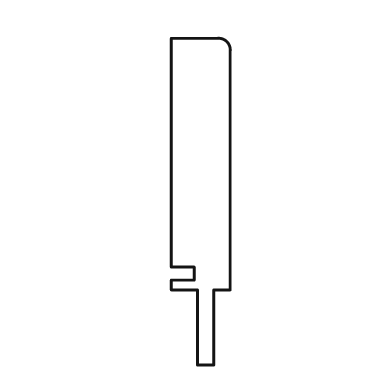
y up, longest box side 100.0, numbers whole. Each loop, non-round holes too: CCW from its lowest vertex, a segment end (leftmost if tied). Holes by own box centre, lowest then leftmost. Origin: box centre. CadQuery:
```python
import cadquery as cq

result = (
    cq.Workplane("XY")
    .moveTo(-1.0, -50.0)
    .lineTo(4.0, -50.0)
    .lineTo(4.0, -27.0)
    .lineTo(9.0, -27.0)
    .lineTo(9.0, 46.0)
    .threePointArc((8.0, 49.0), (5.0, 50.0))
    .lineTo(-9.0, 50.0)
    .lineTo(-9.0, -20.0)
    .lineTo(-2.0, -20.0)
    .lineTo(-2.0, -24.0)
    .lineTo(-9.0, -24.0)
    .lineTo(-9.0, -27.0)
    .lineTo(-1.0, -27.0)
    .close()
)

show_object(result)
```